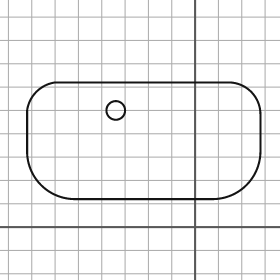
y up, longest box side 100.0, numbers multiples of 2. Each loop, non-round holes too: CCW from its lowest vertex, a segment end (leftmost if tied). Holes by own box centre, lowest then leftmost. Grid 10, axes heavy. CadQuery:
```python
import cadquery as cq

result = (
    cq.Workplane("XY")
    .moveTo(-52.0, 12.0)
    .lineTo(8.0, 12.0)
    .threePointArc((22.0, 18.0), (28.0, 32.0))
    .lineTo(28.0, 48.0)
    .threePointArc((24.0, 58.0), (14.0, 62.0))
    .lineTo(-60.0, 62.0)
    .threePointArc((-68.0, 58.0), (-72.0, 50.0))
    .lineTo(-72.0, 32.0)
    .threePointArc((-66.0, 18.0), (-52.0, 12.0))
    .close()
    .moveTo(-34.0, 50.0)
    .circle(4.0)
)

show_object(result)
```